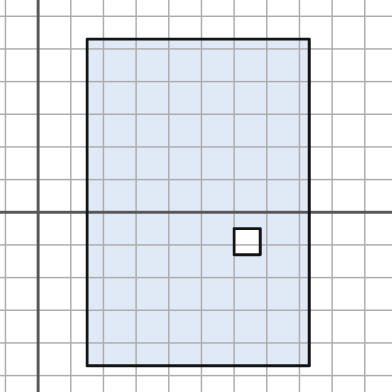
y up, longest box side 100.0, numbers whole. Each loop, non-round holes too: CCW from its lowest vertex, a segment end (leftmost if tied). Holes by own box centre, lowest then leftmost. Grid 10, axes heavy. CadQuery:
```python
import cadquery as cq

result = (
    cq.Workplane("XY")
    .moveTo(15.0, -47.0)
    .lineTo(83.0, -47.0)
    .lineTo(83.0, 53.0)
    .lineTo(15.0, 53.0)
    .close()
    .moveTo(60.0, -13.0)
    .lineTo(68.0, -13.0)
    .lineTo(68.0, -5.0)
    .lineTo(60.0, -5.0)
    .close()
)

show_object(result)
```